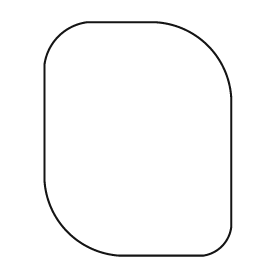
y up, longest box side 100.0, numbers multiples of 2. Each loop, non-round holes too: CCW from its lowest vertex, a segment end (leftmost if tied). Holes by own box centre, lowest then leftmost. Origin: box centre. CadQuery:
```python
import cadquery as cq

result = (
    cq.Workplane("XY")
    .moveTo(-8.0, -50.0)
    .lineTo(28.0, -50.0)
    .threePointArc((36.0, -46.0), (40.0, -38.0))
    .lineTo(40.0, 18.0)
    .threePointArc((30.0, 40.0), (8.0, 50.0))
    .lineTo(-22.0, 50.0)
    .threePointArc((-34.0, 44.0), (-40.0, 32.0))
    .lineTo(-40.0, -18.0)
    .threePointArc((-30.0, -40.0), (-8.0, -50.0))
    .close()
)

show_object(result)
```